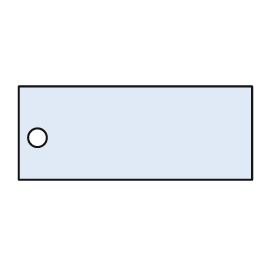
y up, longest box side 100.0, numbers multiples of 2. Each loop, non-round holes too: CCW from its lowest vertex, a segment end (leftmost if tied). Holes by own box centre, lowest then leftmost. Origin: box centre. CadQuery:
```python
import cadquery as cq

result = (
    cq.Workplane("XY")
    .moveTo(-50.0, -20.0)
    .lineTo(50.0, -20.0)
    .lineTo(50.0, 20.0)
    .lineTo(-50.0, 20.0)
    .close()
    .moveTo(-42.0, -2.0)
    .circle(4.0)
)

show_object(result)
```